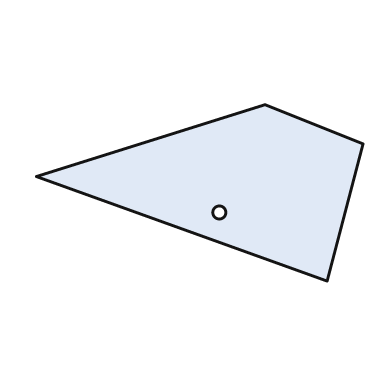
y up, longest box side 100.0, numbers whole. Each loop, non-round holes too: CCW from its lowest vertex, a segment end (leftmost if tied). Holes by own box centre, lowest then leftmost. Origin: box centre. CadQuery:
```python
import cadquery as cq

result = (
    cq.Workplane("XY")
    .moveTo(39.0, -27.0)
    .lineTo(50.0, 15.0)
    .lineTo(20.0, 27.0)
    .lineTo(-50.0, 5.0)
    .close()
    .moveTo(6.0, -6.0)
    .circle(2.0)
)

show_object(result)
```